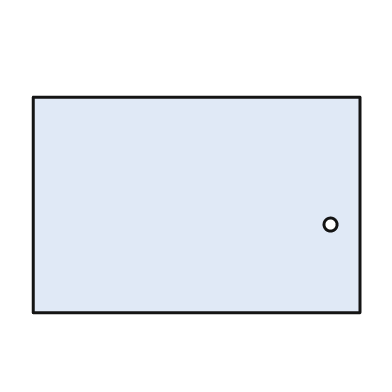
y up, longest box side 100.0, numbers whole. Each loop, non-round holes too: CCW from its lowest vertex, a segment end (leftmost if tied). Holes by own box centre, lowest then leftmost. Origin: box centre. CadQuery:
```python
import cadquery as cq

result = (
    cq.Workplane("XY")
    .moveTo(-50.0, -33.0)
    .lineTo(50.0, -33.0)
    .lineTo(50.0, 33.0)
    .lineTo(-50.0, 33.0)
    .close()
    .moveTo(41.0, -6.0)
    .circle(2.0)
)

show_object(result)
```